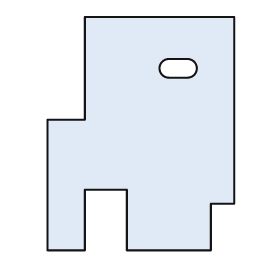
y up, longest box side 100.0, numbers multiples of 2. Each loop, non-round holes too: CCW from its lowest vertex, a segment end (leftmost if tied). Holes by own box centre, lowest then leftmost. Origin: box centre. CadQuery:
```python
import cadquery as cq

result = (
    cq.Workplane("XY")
    .moveTo(-40.0, -50.0)
    .lineTo(-24.0, -50.0)
    .lineTo(-24.0, -24.0)
    .lineTo(-6.0, -24.0)
    .lineTo(-6.0, -50.0)
    .lineTo(30.0, -50.0)
    .lineTo(30.0, -30.0)
    .lineTo(40.0, -30.0)
    .lineTo(40.0, 50.0)
    .lineTo(-24.0, 50.0)
    .lineTo(-24.0, 6.0)
    .lineTo(-40.0, 6.0)
    .close()
    .moveTo(12.0, 24.0)
    .lineTo(20.0, 24.0)
    .threePointArc((24.0, 28.0), (20.0, 32.0))
    .lineTo(12.0, 32.0)
    .threePointArc((8.0, 28.0), (12.0, 24.0))
    .close()
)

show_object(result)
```